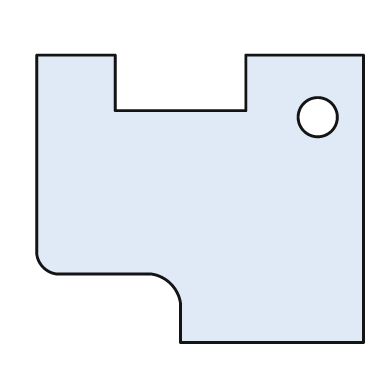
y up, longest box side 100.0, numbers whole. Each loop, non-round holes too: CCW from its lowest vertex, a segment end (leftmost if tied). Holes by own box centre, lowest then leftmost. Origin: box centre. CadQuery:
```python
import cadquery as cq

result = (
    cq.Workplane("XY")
    .moveTo(-6.0, -44.0)
    .lineTo(50.0, -44.0)
    .lineTo(50.0, 44.0)
    .lineTo(14.0, 44.0)
    .lineTo(14.0, 27.0)
    .lineTo(-26.0, 27.0)
    .lineTo(-26.0, 44.0)
    .lineTo(-50.0, 44.0)
    .lineTo(-50.0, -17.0)
    .threePointArc((-48.0, -21.0), (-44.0, -23.0))
    .lineTo(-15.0, -23.0)
    .threePointArc((-9.0, -26.0), (-6.0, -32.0))
    .close()
    .moveTo(36.0, 25.0)
    .circle(6.0)
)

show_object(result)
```